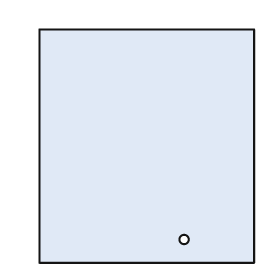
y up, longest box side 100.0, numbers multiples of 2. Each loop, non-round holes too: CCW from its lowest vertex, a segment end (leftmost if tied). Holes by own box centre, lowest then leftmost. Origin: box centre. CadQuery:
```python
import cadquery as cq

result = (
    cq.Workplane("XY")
    .moveTo(-46.0, -50.0)
    .lineTo(46.0, -50.0)
    .lineTo(46.0, 50.0)
    .lineTo(-46.0, 50.0)
    .close()
    .moveTo(16.0, -40.0)
    .circle(2.0)
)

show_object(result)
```